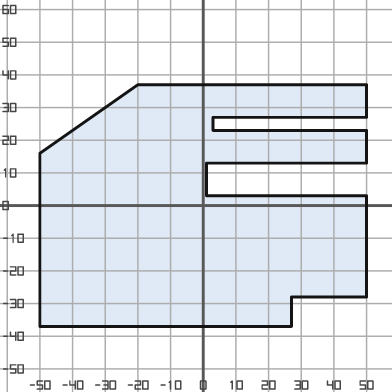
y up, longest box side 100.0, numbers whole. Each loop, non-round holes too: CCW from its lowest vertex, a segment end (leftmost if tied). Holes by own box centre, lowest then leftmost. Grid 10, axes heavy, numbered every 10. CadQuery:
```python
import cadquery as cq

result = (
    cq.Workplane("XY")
    .moveTo(-50.0, -37.0)
    .lineTo(27.0, -37.0)
    .lineTo(27.0, -28.0)
    .lineTo(50.0, -28.0)
    .lineTo(50.0, 3.0)
    .lineTo(1.0, 3.0)
    .lineTo(1.0, 13.0)
    .lineTo(50.0, 13.0)
    .lineTo(50.0, 23.0)
    .lineTo(3.0, 23.0)
    .lineTo(3.0, 27.0)
    .lineTo(50.0, 27.0)
    .lineTo(50.0, 37.0)
    .lineTo(-20.0, 37.0)
    .lineTo(-50.0, 16.0)
    .close()
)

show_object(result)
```